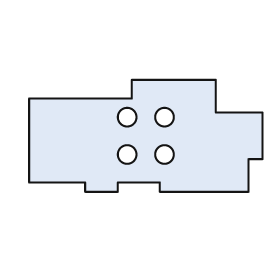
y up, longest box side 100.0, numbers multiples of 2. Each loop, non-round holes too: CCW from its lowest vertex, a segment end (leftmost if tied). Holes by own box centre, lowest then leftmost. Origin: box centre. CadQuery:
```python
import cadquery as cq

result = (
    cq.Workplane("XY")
    .moveTo(-26.0, -24.0)
    .lineTo(-12.0, -24.0)
    .lineTo(-12.0, -20.0)
    .lineTo(6.0, -20.0)
    .lineTo(6.0, -24.0)
    .lineTo(44.0, -24.0)
    .lineTo(44.0, -10.0)
    .lineTo(50.0, -10.0)
    .lineTo(50.0, 10.0)
    .lineTo(30.0, 10.0)
    .lineTo(30.0, 24.0)
    .lineTo(-6.0, 24.0)
    .lineTo(-6.0, 16.0)
    .lineTo(-50.0, 16.0)
    .lineTo(-50.0, -20.0)
    .lineTo(-26.0, -20.0)
    .close()
    .moveTo(-8.0, -8.0)
    .circle(4.0)
    .moveTo(8.0, -8.0)
    .circle(4.0)
    .moveTo(-8.0, 8.0)
    .circle(4.0)
    .moveTo(8.0, 8.0)
    .circle(4.0)
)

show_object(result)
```